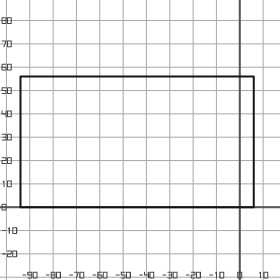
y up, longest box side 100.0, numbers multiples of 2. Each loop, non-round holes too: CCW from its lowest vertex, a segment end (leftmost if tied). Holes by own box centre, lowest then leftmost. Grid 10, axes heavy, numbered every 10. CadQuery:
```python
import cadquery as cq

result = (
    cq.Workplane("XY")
    .moveTo(-94.0, 0.0)
    .lineTo(6.0, 0.0)
    .lineTo(6.0, 56.0)
    .lineTo(-94.0, 56.0)
    .close()
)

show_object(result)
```